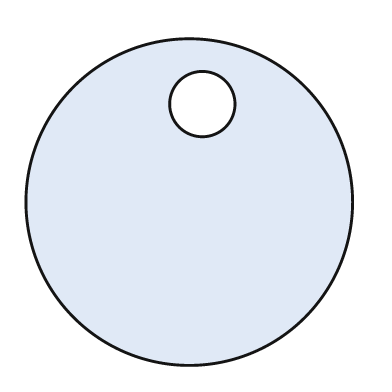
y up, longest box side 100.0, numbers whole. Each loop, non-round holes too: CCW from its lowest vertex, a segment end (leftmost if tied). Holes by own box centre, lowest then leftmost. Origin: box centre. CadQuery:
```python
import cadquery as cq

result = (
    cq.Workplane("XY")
    .moveTo(0.0, 0.0)
    .circle(50.0)
    .moveTo(4.0, 30.0)
    .circle(10.0)
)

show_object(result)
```